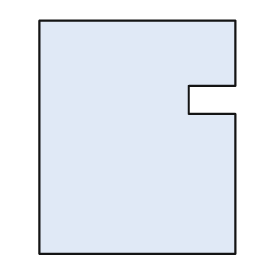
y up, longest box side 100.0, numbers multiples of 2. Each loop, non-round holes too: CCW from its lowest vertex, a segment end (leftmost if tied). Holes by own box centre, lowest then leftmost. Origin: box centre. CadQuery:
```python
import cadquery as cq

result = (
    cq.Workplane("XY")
    .moveTo(-42.0, -50.0)
    .lineTo(42.0, -50.0)
    .lineTo(42.0, 10.0)
    .lineTo(22.0, 10.0)
    .lineTo(22.0, 22.0)
    .lineTo(42.0, 22.0)
    .lineTo(42.0, 50.0)
    .lineTo(-42.0, 50.0)
    .close()
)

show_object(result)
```